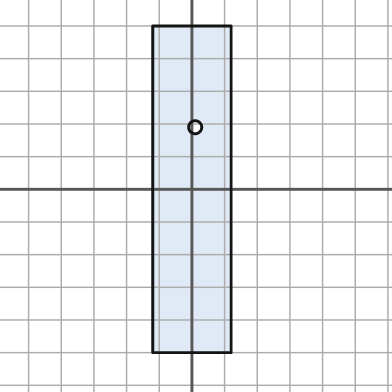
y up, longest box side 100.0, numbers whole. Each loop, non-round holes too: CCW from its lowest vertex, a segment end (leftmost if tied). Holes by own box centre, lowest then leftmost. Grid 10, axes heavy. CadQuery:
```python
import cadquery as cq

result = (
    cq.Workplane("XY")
    .moveTo(-12.0, -50.0)
    .lineTo(12.0, -50.0)
    .lineTo(12.0, 50.0)
    .lineTo(-12.0, 50.0)
    .close()
    .moveTo(1.0, 19.0)
    .circle(2.0)
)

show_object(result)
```